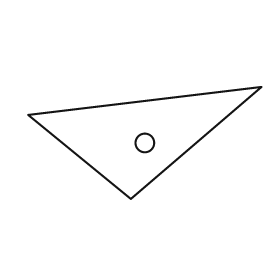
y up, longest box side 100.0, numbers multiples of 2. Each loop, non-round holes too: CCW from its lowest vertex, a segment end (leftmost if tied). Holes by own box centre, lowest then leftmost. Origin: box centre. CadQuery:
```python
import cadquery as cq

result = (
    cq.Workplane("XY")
    .moveTo(-6.0, -24.0)
    .lineTo(50.0, 24.0)
    .lineTo(-50.0, 12.0)
    .close()
    .moveTo(0.0, 0.0)
    .circle(4.0)
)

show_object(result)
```